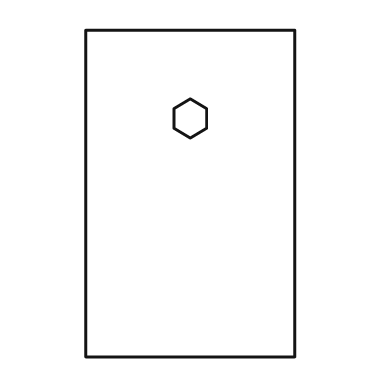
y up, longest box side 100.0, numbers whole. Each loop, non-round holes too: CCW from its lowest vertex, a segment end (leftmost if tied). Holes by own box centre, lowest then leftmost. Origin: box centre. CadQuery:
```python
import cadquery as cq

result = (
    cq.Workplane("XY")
    .moveTo(-32.0, -50.0)
    .lineTo(32.0, -50.0)
    .lineTo(32.0, 50.0)
    .lineTo(-32.0, 50.0)
    .close()
    .moveTo(0.0, 17.0)
    .lineTo(5.0, 20.0)
    .lineTo(5.0, 26.0)
    .lineTo(0.0, 29.0)
    .lineTo(-5.0, 26.0)
    .lineTo(-5.0, 20.0)
    .close()
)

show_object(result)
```